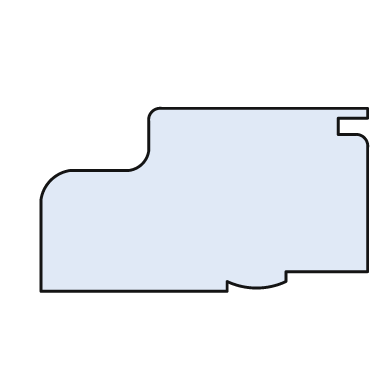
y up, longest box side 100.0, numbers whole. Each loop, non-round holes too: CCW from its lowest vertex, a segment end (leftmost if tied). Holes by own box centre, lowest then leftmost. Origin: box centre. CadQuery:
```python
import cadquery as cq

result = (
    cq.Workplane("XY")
    .moveTo(-50.0, -28.0)
    .lineTo(7.0, -28.0)
    .lineTo(7.0, -25.0)
    .threePointArc((16.0, -27.0), (25.0, -25.0))
    .lineTo(25.0, -22.0)
    .lineTo(50.0, -22.0)
    .lineTo(50.0, 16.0)
    .threePointArc((49.0, 19.0), (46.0, 20.0))
    .lineTo(41.0, 20.0)
    .lineTo(41.0, 25.0)
    .lineTo(50.0, 25.0)
    .lineTo(50.0, 28.0)
    .lineTo(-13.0, 28.0)
    .threePointArc((-16.0, 27.0), (-17.0, 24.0))
    .lineTo(-17.0, 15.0)
    .threePointArc((-19.0, 11.0), (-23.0, 9.0))
    .lineTo(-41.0, 9.0)
    .threePointArc((-47.0, 6.0), (-50.0, 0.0))
    .close()
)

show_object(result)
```